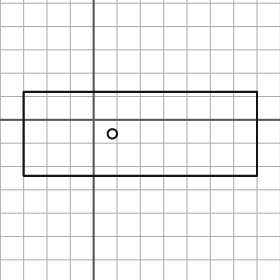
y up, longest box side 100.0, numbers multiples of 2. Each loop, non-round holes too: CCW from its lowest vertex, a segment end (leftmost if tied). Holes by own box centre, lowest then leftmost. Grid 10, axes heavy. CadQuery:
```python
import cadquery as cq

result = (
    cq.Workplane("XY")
    .moveTo(-30.0, -24.0)
    .lineTo(70.0, -24.0)
    .lineTo(70.0, 12.0)
    .lineTo(-30.0, 12.0)
    .close()
    .moveTo(8.0, -6.0)
    .circle(2.0)
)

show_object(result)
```